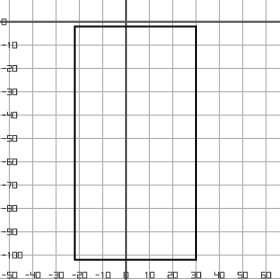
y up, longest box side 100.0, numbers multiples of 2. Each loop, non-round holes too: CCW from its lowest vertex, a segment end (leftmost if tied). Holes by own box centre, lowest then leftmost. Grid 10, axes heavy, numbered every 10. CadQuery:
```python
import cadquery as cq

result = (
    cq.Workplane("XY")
    .moveTo(-22.0, -102.0)
    .lineTo(30.0, -102.0)
    .lineTo(30.0, -2.0)
    .lineTo(-22.0, -2.0)
    .close()
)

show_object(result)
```